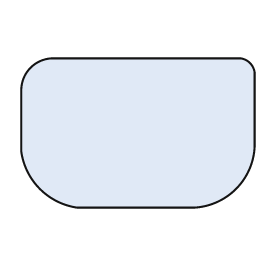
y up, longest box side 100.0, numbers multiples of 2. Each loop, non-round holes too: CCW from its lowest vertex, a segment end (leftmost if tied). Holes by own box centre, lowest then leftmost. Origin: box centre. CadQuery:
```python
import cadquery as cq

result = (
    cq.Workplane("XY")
    .moveTo(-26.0, -32.0)
    .lineTo(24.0, -32.0)
    .threePointArc((42.0, -24.0), (50.0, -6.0))
    .lineTo(50.0, 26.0)
    .threePointArc((48.0, 30.0), (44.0, 32.0))
    .lineTo(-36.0, 32.0)
    .threePointArc((-46.0, 28.0), (-50.0, 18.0))
    .lineTo(-50.0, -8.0)
    .threePointArc((-42.0, -24.0), (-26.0, -32.0))
    .close()
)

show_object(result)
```